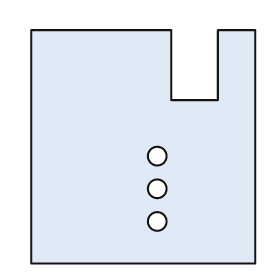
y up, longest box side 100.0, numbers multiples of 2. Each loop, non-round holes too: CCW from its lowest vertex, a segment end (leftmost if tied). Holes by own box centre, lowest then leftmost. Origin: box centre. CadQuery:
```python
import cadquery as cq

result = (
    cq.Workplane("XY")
    .moveTo(-48.0, -50.0)
    .lineTo(48.0, -50.0)
    .lineTo(48.0, 50.0)
    .lineTo(32.0, 50.0)
    .lineTo(32.0, 20.0)
    .lineTo(12.0, 20.0)
    .lineTo(12.0, 50.0)
    .lineTo(-48.0, 50.0)
    .close()
    .moveTo(6.0, -32.0)
    .circle(4.0)
    .moveTo(6.0, -18.0)
    .circle(4.0)
    .moveTo(6.0, -4.0)
    .circle(4.0)
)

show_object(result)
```